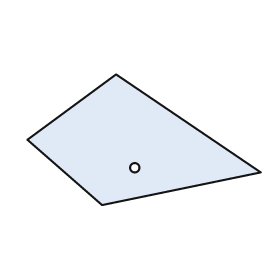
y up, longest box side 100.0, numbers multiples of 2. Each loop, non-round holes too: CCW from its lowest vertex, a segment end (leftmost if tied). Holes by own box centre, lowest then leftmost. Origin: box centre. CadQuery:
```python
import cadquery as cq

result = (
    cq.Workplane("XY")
    .moveTo(-18.0, -28.0)
    .lineTo(50.0, -14.0)
    .lineTo(-12.0, 28.0)
    .lineTo(-50.0, 0.0)
    .close()
    .moveTo(-4.0, -12.0)
    .circle(2.0)
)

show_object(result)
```